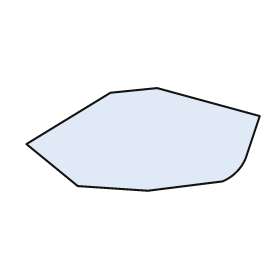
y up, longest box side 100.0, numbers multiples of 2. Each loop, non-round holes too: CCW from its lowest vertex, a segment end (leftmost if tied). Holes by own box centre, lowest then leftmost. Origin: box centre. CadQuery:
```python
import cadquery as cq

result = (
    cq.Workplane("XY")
    .moveTo(2.0, -22.0)
    .lineTo(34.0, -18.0)
    .threePointArc((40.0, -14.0), (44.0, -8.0))
    .lineTo(50.0, 10.0)
    .lineTo(6.0, 22.0)
    .lineTo(-14.0, 20.0)
    .lineTo(-50.0, -2.0)
    .lineTo(-28.0, -20.0)
    .close()
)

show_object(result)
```